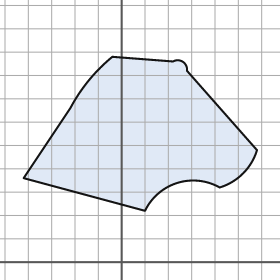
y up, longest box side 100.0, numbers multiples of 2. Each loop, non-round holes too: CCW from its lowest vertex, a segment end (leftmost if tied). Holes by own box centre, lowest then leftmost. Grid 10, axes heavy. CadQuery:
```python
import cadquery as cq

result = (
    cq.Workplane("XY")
    .moveTo(10.0, 22.0)
    .threePointArc((24.0, 34.0), (42.0, 32.0))
    .threePointArc((52.0, 38.0), (58.0, 48.0))
    .lineTo(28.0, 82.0)
    .threePointArc((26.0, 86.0), (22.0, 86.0))
    .lineTo(-4.0, 88.0)
    .threePointArc((-14.0, 78.0), (-22.0, 66.0))
    .lineTo(-42.0, 36.0)
    .close()
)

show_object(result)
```